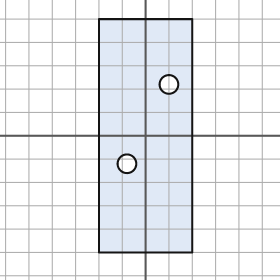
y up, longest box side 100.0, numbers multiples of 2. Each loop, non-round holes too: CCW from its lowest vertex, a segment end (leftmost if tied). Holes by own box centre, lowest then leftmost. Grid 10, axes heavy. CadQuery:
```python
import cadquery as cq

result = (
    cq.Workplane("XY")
    .moveTo(-20.0, -50.0)
    .lineTo(20.0, -50.0)
    .lineTo(20.0, 50.0)
    .lineTo(-20.0, 50.0)
    .close()
    .moveTo(-8.0, -12.0)
    .circle(4.0)
    .moveTo(10.0, 22.0)
    .circle(4.0)
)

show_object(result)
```